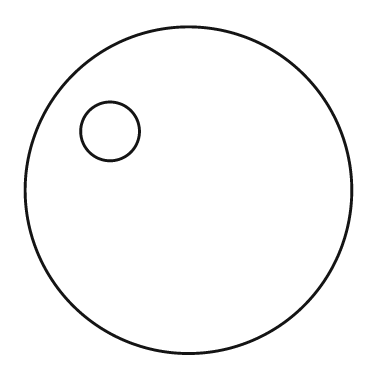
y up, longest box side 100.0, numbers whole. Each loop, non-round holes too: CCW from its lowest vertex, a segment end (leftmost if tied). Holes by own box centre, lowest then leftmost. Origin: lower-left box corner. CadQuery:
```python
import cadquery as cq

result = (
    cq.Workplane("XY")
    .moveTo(50.0, 50.0)
    .circle(50.0)
    .moveTo(26.0, 68.0)
    .circle(9.0)
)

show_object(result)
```